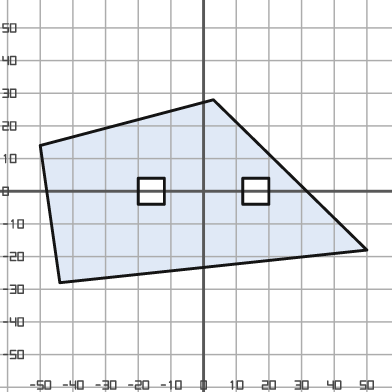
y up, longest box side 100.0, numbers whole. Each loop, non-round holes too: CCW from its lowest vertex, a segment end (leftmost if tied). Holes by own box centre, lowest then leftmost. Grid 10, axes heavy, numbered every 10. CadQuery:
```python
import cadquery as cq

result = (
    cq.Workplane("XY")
    .moveTo(-44.0, -28.0)
    .lineTo(50.0, -18.0)
    .lineTo(3.0, 28.0)
    .lineTo(-50.0, 14.0)
    .close()
    .moveTo(-20.0, -4.0)
    .lineTo(-12.0, -4.0)
    .lineTo(-12.0, 4.0)
    .lineTo(-20.0, 4.0)
    .close()
    .moveTo(12.0, -4.0)
    .lineTo(20.0, -4.0)
    .lineTo(20.0, 4.0)
    .lineTo(12.0, 4.0)
    .close()
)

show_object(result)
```